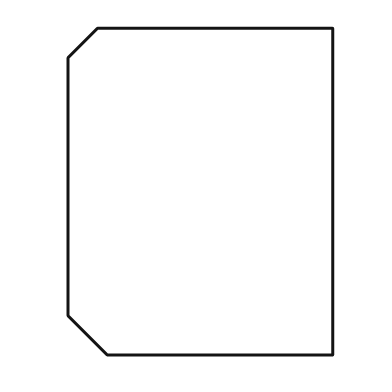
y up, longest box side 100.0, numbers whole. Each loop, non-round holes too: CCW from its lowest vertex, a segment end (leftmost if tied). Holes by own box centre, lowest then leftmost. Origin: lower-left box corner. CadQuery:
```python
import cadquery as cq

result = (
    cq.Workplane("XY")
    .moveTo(12.0, 0.0)
    .lineTo(81.0, 0.0)
    .lineTo(81.0, 100.0)
    .lineTo(9.0, 100.0)
    .lineTo(0.0, 91.0)
    .lineTo(0.0, 12.0)
    .close()
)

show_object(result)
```